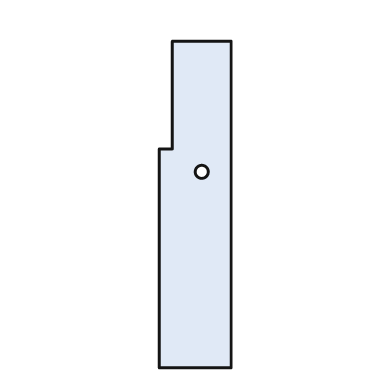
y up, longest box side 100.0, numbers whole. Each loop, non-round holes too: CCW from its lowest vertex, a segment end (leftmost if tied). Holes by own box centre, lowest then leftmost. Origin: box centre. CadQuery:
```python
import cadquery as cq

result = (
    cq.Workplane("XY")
    .moveTo(-11.0, -50.0)
    .lineTo(11.0, -50.0)
    .lineTo(11.0, 50.0)
    .lineTo(-7.0, 50.0)
    .lineTo(-7.0, 17.0)
    .lineTo(-11.0, 17.0)
    .close()
    .moveTo(2.0, 10.0)
    .circle(2.0)
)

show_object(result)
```